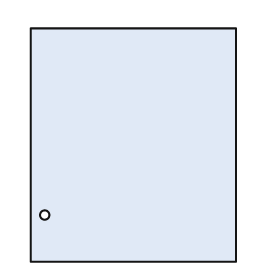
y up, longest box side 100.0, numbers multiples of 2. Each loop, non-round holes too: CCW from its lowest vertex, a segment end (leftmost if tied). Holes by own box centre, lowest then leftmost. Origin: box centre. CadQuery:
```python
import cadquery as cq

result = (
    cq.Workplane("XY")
    .moveTo(-44.0, -50.0)
    .lineTo(44.0, -50.0)
    .lineTo(44.0, 50.0)
    .lineTo(-44.0, 50.0)
    .close()
    .moveTo(-38.0, -30.0)
    .circle(2.0)
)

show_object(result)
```